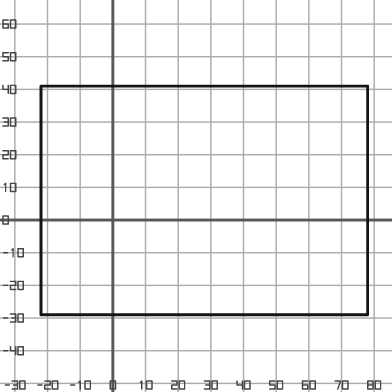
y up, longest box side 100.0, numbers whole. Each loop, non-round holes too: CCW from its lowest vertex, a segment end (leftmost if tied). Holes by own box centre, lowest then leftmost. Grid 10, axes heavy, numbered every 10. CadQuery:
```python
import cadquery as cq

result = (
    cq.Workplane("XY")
    .moveTo(-22.0, -29.0)
    .lineTo(78.0, -29.0)
    .lineTo(78.0, 41.0)
    .lineTo(-22.0, 41.0)
    .close()
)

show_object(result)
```